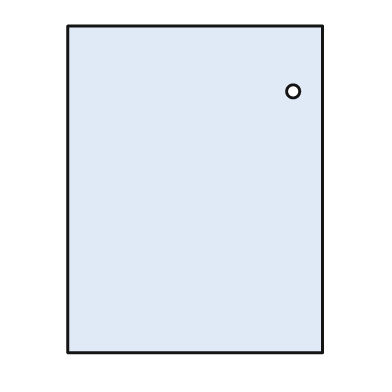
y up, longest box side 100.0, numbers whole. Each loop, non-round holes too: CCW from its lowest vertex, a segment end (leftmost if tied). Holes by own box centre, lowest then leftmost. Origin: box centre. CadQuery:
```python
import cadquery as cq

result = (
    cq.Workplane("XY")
    .moveTo(-39.0, -50.0)
    .lineTo(39.0, -50.0)
    .lineTo(39.0, 50.0)
    .lineTo(-39.0, 50.0)
    .close()
    .moveTo(30.0, 30.0)
    .circle(2.0)
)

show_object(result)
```